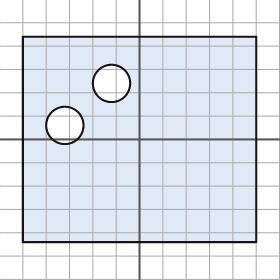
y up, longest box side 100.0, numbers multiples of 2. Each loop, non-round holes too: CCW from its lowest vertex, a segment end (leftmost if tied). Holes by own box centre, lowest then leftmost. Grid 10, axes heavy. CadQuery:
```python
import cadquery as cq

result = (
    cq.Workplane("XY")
    .moveTo(-50.0, -44.0)
    .lineTo(50.0, -44.0)
    .lineTo(50.0, 44.0)
    .lineTo(-50.0, 44.0)
    .close()
    .moveTo(-32.0, 6.0)
    .circle(8.0)
    .moveTo(-12.0, 24.0)
    .circle(8.0)
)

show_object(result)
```